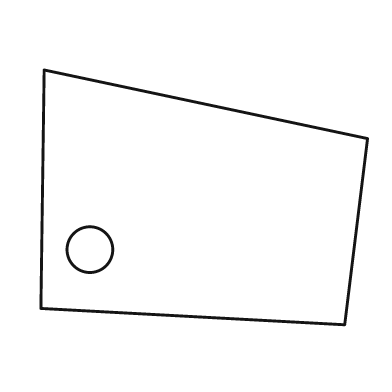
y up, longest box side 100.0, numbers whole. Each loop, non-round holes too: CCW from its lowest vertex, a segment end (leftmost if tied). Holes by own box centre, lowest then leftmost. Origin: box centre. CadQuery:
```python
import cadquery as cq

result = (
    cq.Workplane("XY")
    .moveTo(43.0, -39.0)
    .lineTo(50.0, 18.0)
    .lineTo(-49.0, 39.0)
    .lineTo(-50.0, -34.0)
    .close()
    .moveTo(-35.0, -16.0)
    .circle(7.0)
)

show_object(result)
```